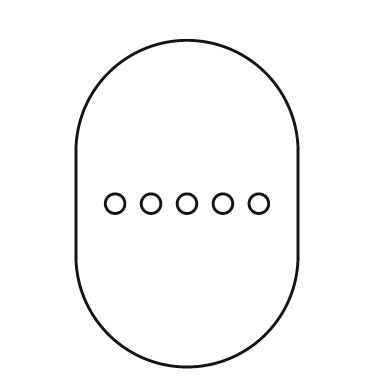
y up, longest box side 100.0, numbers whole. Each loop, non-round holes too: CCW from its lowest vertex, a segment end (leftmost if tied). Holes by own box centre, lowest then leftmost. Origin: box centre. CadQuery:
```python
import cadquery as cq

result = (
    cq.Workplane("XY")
    .moveTo(-34.0, -16.0)
    .threePointArc((0.0, -50.0), (34.0, -16.0))
    .lineTo(34.0, 16.0)
    .threePointArc((0.0, 50.0), (-34.0, 16.0))
    .close()
    .moveTo(-22.0, 0.0)
    .circle(3.0)
    .moveTo(-11.0, 0.0)
    .circle(3.0)
    .moveTo(0.0, 0.0)
    .circle(3.0)
    .moveTo(11.0, 0.0)
    .circle(3.0)
    .moveTo(22.0, 0.0)
    .circle(3.0)
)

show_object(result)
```